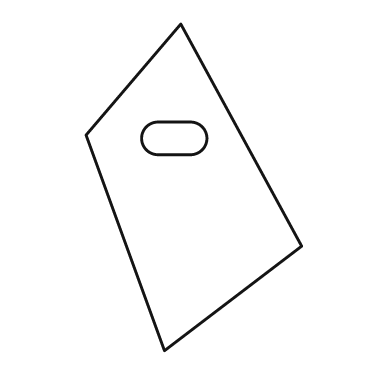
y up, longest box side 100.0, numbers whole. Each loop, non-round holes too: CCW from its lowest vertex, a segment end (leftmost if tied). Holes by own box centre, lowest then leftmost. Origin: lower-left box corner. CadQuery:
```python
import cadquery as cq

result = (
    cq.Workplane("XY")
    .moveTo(24.0, 0.0)
    .lineTo(66.0, 32.0)
    .lineTo(29.0, 100.0)
    .lineTo(0.0, 66.0)
    .close()
    .moveTo(22.0, 60.0)
    .lineTo(32.0, 60.0)
    .threePointArc((37.0, 65.0), (32.0, 70.0))
    .lineTo(22.0, 70.0)
    .threePointArc((17.0, 65.0), (22.0, 60.0))
    .close()
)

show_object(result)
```